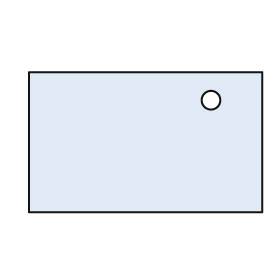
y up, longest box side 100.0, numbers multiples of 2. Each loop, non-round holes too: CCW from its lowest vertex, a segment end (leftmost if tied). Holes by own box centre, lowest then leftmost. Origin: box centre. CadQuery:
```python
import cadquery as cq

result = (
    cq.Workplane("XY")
    .moveTo(-50.0, -30.0)
    .lineTo(50.0, -30.0)
    .lineTo(50.0, 30.0)
    .lineTo(-50.0, 30.0)
    .close()
    .moveTo(28.0, 18.0)
    .circle(4.0)
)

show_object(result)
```